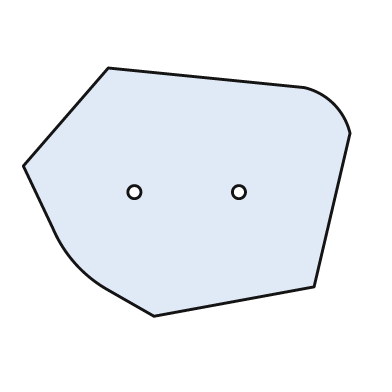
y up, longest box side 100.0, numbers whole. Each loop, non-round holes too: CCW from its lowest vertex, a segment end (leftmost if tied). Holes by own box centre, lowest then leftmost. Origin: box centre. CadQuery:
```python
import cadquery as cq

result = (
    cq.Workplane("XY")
    .moveTo(-10.0, -38.0)
    .lineTo(39.0, -29.0)
    .lineTo(50.0, 18.0)
    .threePointArc((45.0, 27.0), (36.0, 32.0))
    .lineTo(-24.0, 38.0)
    .lineTo(-50.0, 8.0)
    .lineTo(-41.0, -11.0)
    .threePointArc((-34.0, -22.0), (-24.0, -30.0))
    .close()
    .moveTo(-16.0, 0.0)
    .circle(2.0)
    .moveTo(16.0, 0.0)
    .circle(2.0)
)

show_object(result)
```